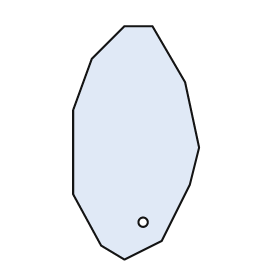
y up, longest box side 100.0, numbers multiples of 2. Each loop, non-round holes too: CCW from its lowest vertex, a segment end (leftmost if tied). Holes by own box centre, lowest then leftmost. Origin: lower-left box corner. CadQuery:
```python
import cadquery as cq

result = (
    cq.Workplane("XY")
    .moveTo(22.0, 0.0)
    .lineTo(38.0, 8.0)
    .lineTo(50.0, 32.0)
    .lineTo(54.0, 48.0)
    .lineTo(48.0, 76.0)
    .lineTo(34.0, 100.0)
    .lineTo(22.0, 100.0)
    .lineTo(8.0, 86.0)
    .lineTo(0.0, 64.0)
    .lineTo(0.0, 28.0)
    .lineTo(12.0, 6.0)
    .close()
    .moveTo(30.0, 16.0)
    .circle(2.0)
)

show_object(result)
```